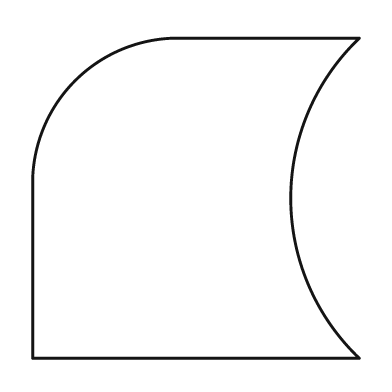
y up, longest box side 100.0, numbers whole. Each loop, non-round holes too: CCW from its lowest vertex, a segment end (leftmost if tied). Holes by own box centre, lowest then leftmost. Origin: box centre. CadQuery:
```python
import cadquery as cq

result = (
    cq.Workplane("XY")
    .moveTo(-50.0, -49.0)
    .lineTo(50.0, -49.0)
    .threePointArc((29.0, 0.0), (50.0, 49.0))
    .lineTo(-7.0, 49.0)
    .threePointArc((-37.0, 36.0), (-50.0, 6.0))
    .close()
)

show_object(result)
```